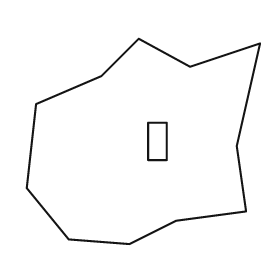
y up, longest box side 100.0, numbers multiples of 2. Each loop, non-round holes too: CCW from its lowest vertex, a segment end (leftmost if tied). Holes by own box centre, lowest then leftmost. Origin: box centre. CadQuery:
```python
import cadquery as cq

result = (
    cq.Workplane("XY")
    .moveTo(-6.0, -44.0)
    .lineTo(14.0, -34.0)
    .lineTo(44.0, -30.0)
    .lineTo(40.0, -2.0)
    .lineTo(50.0, 42.0)
    .lineTo(20.0, 32.0)
    .lineTo(-2.0, 44.0)
    .lineTo(-18.0, 28.0)
    .lineTo(-46.0, 16.0)
    .lineTo(-50.0, -20.0)
    .lineTo(-32.0, -42.0)
    .close()
    .moveTo(2.0, -8.0)
    .lineTo(10.0, -8.0)
    .lineTo(10.0, 8.0)
    .lineTo(2.0, 8.0)
    .close()
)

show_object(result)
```